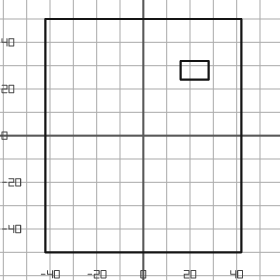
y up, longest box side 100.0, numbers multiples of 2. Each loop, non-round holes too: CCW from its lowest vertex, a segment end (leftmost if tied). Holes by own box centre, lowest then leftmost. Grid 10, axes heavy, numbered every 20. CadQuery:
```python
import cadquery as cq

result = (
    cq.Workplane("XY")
    .moveTo(-42.0, -50.0)
    .lineTo(42.0, -50.0)
    .lineTo(42.0, 50.0)
    .lineTo(-42.0, 50.0)
    .close()
    .moveTo(16.0, 24.0)
    .lineTo(28.0, 24.0)
    .lineTo(28.0, 32.0)
    .lineTo(16.0, 32.0)
    .close()
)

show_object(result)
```